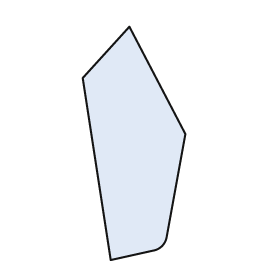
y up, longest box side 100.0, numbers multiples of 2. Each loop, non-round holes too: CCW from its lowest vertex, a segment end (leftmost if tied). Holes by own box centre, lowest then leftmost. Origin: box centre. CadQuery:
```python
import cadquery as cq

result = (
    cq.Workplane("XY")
    .moveTo(-10.0, -50.0)
    .lineTo(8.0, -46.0)
    .threePointArc((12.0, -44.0), (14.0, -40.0))
    .lineTo(22.0, 4.0)
    .lineTo(-2.0, 50.0)
    .lineTo(-22.0, 28.0)
    .close()
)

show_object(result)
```